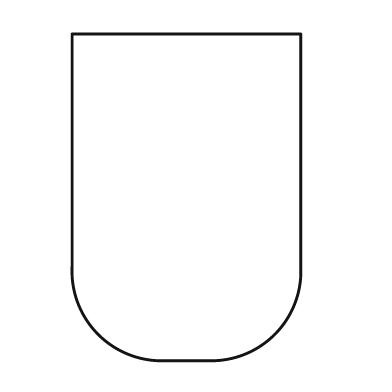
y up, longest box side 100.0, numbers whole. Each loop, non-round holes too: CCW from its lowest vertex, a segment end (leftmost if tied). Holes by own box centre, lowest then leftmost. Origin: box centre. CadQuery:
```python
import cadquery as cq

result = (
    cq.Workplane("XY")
    .moveTo(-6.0, -50.0)
    .lineTo(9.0, -50.0)
    .threePointArc((27.0, -42.0), (35.0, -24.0))
    .lineTo(35.0, 50.0)
    .lineTo(-35.0, 50.0)
    .lineTo(-35.0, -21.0)
    .threePointArc((-27.0, -42.0), (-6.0, -50.0))
    .close()
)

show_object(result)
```